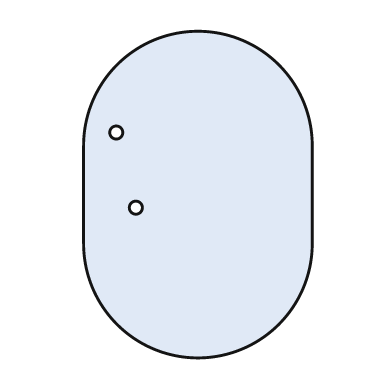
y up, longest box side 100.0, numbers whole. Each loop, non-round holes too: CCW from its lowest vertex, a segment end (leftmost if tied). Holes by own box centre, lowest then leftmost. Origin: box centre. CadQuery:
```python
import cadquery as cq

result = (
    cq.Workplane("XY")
    .moveTo(-35.0, -15.0)
    .threePointArc((0.0, -50.0), (35.0, -15.0))
    .lineTo(35.0, 15.0)
    .threePointArc((0.0, 50.0), (-35.0, 15.0))
    .close()
    .moveTo(-19.0, -4.0)
    .circle(2.0)
    .moveTo(-25.0, 19.0)
    .circle(2.0)
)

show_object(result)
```